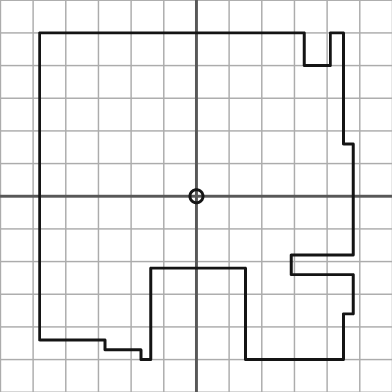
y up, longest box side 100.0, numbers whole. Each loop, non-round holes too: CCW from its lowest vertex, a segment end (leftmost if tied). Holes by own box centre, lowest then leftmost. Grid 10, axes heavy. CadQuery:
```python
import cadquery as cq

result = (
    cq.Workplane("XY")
    .moveTo(-17.0, -50.0)
    .lineTo(-14.0, -50.0)
    .lineTo(-14.0, -22.0)
    .lineTo(15.0, -22.0)
    .lineTo(15.0, -50.0)
    .lineTo(45.0, -50.0)
    .lineTo(45.0, -36.0)
    .lineTo(48.0, -36.0)
    .lineTo(48.0, -24.0)
    .lineTo(29.0, -24.0)
    .lineTo(29.0, -18.0)
    .lineTo(48.0, -18.0)
    .lineTo(48.0, 16.0)
    .lineTo(45.0, 16.0)
    .lineTo(45.0, 50.0)
    .lineTo(41.0, 50.0)
    .lineTo(41.0, 40.0)
    .lineTo(33.0, 40.0)
    .lineTo(33.0, 50.0)
    .lineTo(-48.0, 50.0)
    .lineTo(-48.0, -44.0)
    .lineTo(-28.0, -44.0)
    .lineTo(-28.0, -47.0)
    .lineTo(-17.0, -47.0)
    .close()
    .moveTo(0.0, 0.0)
    .circle(2.0)
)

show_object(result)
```